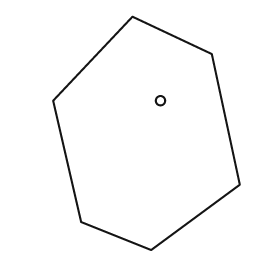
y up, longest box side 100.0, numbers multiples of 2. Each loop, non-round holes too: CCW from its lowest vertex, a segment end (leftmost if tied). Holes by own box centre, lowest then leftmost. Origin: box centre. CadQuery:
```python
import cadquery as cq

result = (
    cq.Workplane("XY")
    .moveTo(2.0, -50.0)
    .lineTo(40.0, -22.0)
    .lineTo(28.0, 34.0)
    .lineTo(-6.0, 50.0)
    .lineTo(-40.0, 14.0)
    .lineTo(-28.0, -38.0)
    .close()
    .moveTo(6.0, 14.0)
    .circle(2.0)
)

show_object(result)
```